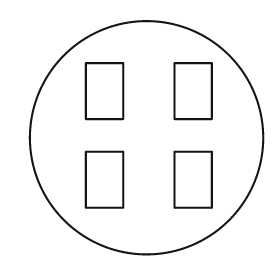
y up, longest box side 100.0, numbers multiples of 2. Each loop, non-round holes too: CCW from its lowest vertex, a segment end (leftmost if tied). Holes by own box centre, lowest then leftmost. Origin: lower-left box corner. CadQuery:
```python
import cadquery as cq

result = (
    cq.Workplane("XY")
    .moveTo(50.0, 50.0)
    .circle(50.0)
    .moveTo(24.0, 20.0)
    .lineTo(40.0, 20.0)
    .lineTo(40.0, 44.0)
    .lineTo(24.0, 44.0)
    .close()
    .moveTo(62.0, 20.0)
    .lineTo(78.0, 20.0)
    .lineTo(78.0, 44.0)
    .lineTo(62.0, 44.0)
    .close()
    .moveTo(24.0, 58.0)
    .lineTo(40.0, 58.0)
    .lineTo(40.0, 82.0)
    .lineTo(24.0, 82.0)
    .close()
    .moveTo(62.0, 58.0)
    .lineTo(78.0, 58.0)
    .lineTo(78.0, 82.0)
    .lineTo(62.0, 82.0)
    .close()
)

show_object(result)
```